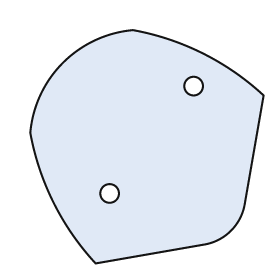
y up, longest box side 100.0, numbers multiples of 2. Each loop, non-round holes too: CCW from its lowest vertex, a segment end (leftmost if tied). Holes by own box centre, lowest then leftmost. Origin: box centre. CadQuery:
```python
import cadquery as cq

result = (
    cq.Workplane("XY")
    .moveTo(-22.0, -50.0)
    .lineTo(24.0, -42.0)
    .threePointArc((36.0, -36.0), (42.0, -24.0))
    .lineTo(50.0, 22.0)
    .threePointArc((24.0, 40.0), (-6.0, 50.0))
    .threePointArc((-36.0, 36.0), (-50.0, 6.0))
    .threePointArc((-40.0, -24.0), (-22.0, -50.0))
    .close()
    .moveTo(-16.0, -20.0)
    .circle(4.0)
    .moveTo(20.0, 26.0)
    .circle(4.0)
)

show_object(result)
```